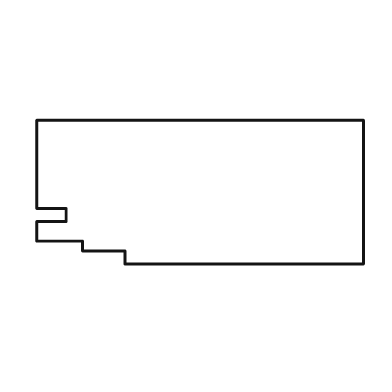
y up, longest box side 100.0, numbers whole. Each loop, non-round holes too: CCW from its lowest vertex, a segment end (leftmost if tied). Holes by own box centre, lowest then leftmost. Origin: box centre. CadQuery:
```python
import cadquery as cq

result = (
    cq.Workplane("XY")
    .moveTo(-23.0, -22.0)
    .lineTo(50.0, -22.0)
    .lineTo(50.0, 22.0)
    .lineTo(-50.0, 22.0)
    .lineTo(-50.0, -5.0)
    .lineTo(-41.0, -5.0)
    .lineTo(-41.0, -9.0)
    .lineTo(-50.0, -9.0)
    .lineTo(-50.0, -15.0)
    .lineTo(-36.0, -15.0)
    .lineTo(-36.0, -18.0)
    .lineTo(-23.0, -18.0)
    .close()
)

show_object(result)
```